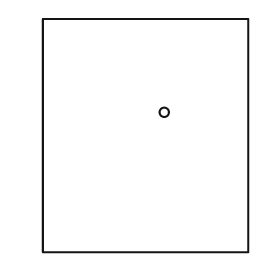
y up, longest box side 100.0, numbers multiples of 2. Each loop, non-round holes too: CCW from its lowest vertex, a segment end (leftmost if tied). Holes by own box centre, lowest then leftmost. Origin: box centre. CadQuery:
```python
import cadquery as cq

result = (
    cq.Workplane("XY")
    .moveTo(-44.0, -50.0)
    .lineTo(44.0, -50.0)
    .lineTo(44.0, 50.0)
    .lineTo(-44.0, 50.0)
    .close()
    .moveTo(8.0, 10.0)
    .circle(2.0)
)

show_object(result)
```